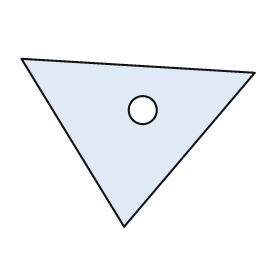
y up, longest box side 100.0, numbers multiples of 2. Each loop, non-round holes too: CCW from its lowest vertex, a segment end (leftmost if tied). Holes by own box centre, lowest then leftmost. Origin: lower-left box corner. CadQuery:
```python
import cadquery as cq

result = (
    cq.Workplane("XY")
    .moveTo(44.0, 0.0)
    .lineTo(100.0, 66.0)
    .lineTo(0.0, 72.0)
    .close()
    .moveTo(52.0, 50.0)
    .circle(6.0)
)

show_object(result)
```